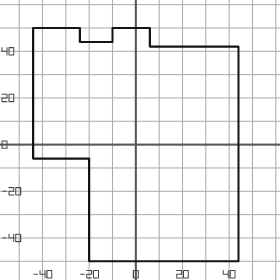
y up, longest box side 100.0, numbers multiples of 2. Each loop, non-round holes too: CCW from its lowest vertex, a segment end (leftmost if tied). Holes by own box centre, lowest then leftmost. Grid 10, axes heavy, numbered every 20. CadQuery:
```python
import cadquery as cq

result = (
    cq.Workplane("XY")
    .moveTo(-20.0, -50.0)
    .lineTo(44.0, -50.0)
    .lineTo(44.0, 42.0)
    .lineTo(6.0, 42.0)
    .lineTo(6.0, 50.0)
    .lineTo(-10.0, 50.0)
    .lineTo(-10.0, 44.0)
    .lineTo(-24.0, 44.0)
    .lineTo(-24.0, 50.0)
    .lineTo(-44.0, 50.0)
    .lineTo(-44.0, -6.0)
    .lineTo(-20.0, -6.0)
    .close()
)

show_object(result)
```